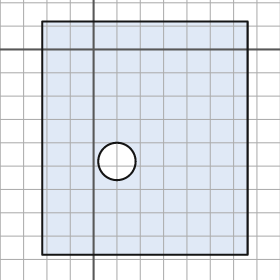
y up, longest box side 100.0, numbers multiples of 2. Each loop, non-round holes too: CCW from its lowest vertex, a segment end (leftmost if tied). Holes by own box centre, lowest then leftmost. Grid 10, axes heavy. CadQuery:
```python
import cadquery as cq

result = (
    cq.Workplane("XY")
    .moveTo(-22.0, -88.0)
    .lineTo(66.0, -88.0)
    .lineTo(66.0, 12.0)
    .lineTo(-22.0, 12.0)
    .close()
    .moveTo(10.0, -48.0)
    .circle(8.0)
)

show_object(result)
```